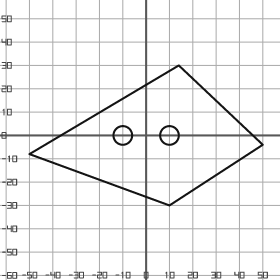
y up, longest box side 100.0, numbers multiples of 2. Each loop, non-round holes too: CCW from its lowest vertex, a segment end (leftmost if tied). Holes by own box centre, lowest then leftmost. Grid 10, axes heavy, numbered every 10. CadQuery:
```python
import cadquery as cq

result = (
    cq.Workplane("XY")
    .moveTo(10.0, -30.0)
    .lineTo(50.0, -4.0)
    .lineTo(14.0, 30.0)
    .lineTo(-50.0, -8.0)
    .close()
    .moveTo(-10.0, 0.0)
    .circle(4.0)
    .moveTo(10.0, 0.0)
    .circle(4.0)
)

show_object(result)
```